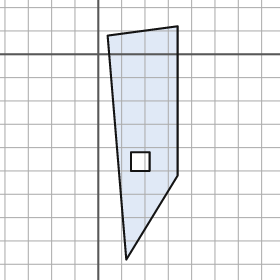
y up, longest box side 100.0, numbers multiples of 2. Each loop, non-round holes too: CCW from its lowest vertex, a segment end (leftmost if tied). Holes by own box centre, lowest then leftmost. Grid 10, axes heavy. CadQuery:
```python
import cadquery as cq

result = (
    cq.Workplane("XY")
    .moveTo(12.0, -88.0)
    .lineTo(34.0, -52.0)
    .lineTo(34.0, 12.0)
    .lineTo(4.0, 8.0)
    .close()
    .moveTo(14.0, -50.0)
    .lineTo(22.0, -50.0)
    .lineTo(22.0, -42.0)
    .lineTo(14.0, -42.0)
    .close()
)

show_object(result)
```